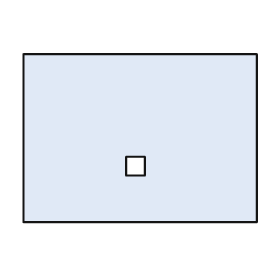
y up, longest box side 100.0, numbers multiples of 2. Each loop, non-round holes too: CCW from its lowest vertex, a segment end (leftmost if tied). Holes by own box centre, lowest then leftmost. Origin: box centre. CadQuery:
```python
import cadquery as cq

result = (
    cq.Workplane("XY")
    .moveTo(-50.0, -36.0)
    .lineTo(50.0, -36.0)
    .lineTo(50.0, 36.0)
    .lineTo(-50.0, 36.0)
    .close()
    .moveTo(-6.0, -16.0)
    .lineTo(2.0, -16.0)
    .lineTo(2.0, -8.0)
    .lineTo(-6.0, -8.0)
    .close()
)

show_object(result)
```